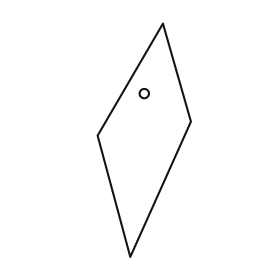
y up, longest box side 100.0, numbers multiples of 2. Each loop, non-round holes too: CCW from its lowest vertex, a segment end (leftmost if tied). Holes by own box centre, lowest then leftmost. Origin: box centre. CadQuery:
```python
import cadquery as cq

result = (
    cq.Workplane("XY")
    .moveTo(-6.0, -50.0)
    .lineTo(20.0, 8.0)
    .lineTo(8.0, 50.0)
    .lineTo(-20.0, 2.0)
    .close()
    .moveTo(0.0, 20.0)
    .circle(2.0)
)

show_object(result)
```